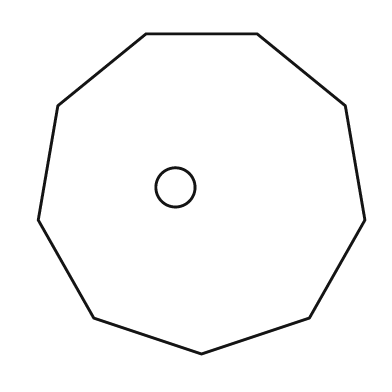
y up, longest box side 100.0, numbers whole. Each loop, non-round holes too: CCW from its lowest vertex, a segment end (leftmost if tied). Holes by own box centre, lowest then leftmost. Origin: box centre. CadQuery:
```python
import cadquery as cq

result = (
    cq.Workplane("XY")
    .moveTo(0.0, -49.0)
    .lineTo(33.0, -38.0)
    .lineTo(50.0, -8.0)
    .lineTo(44.0, 27.0)
    .lineTo(17.0, 49.0)
    .lineTo(-17.0, 49.0)
    .lineTo(-44.0, 27.0)
    .lineTo(-50.0, -8.0)
    .lineTo(-33.0, -38.0)
    .close()
    .moveTo(-8.0, 2.0)
    .circle(6.0)
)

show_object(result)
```